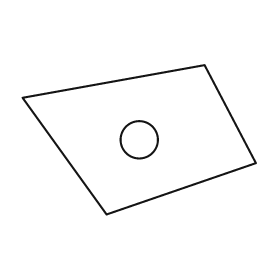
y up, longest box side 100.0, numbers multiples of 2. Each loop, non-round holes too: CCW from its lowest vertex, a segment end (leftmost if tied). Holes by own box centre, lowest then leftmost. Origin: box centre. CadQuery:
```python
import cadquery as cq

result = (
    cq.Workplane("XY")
    .moveTo(-14.0, -32.0)
    .lineTo(50.0, -10.0)
    .lineTo(28.0, 32.0)
    .lineTo(-50.0, 18.0)
    .close()
    .moveTo(0.0, 0.0)
    .circle(8.0)
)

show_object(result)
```